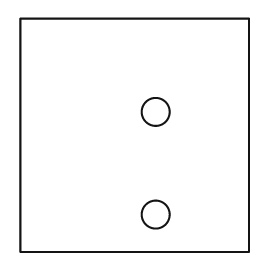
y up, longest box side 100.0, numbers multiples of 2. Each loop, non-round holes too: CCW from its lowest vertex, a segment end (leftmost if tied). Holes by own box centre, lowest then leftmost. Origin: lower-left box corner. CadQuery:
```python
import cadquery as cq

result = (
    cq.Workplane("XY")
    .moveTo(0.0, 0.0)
    .lineTo(98.0, 0.0)
    .lineTo(98.0, 100.0)
    .lineTo(0.0, 100.0)
    .close()
    .moveTo(58.0, 16.0)
    .circle(6.0)
    .moveTo(58.0, 60.0)
    .circle(6.0)
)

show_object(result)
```